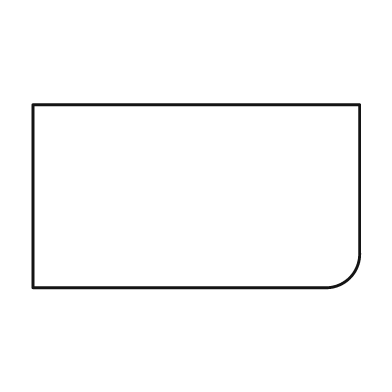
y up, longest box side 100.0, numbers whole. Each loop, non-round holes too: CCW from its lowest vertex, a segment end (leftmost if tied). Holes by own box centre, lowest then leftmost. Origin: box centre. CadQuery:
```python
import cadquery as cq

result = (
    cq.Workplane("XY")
    .moveTo(-50.0, -28.0)
    .lineTo(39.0, -28.0)
    .threePointArc((47.0, -25.0), (50.0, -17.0))
    .lineTo(50.0, 28.0)
    .lineTo(-50.0, 28.0)
    .close()
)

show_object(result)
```